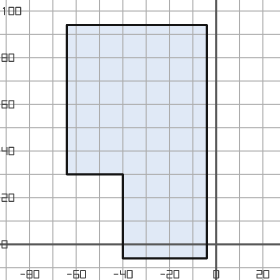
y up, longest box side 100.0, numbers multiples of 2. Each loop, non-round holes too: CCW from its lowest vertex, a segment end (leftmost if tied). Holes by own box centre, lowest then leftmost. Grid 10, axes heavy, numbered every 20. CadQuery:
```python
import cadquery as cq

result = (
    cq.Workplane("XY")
    .moveTo(-40.0, -6.0)
    .lineTo(-4.0, -6.0)
    .lineTo(-4.0, 94.0)
    .lineTo(-64.0, 94.0)
    .lineTo(-64.0, 30.0)
    .lineTo(-40.0, 30.0)
    .close()
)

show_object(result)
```